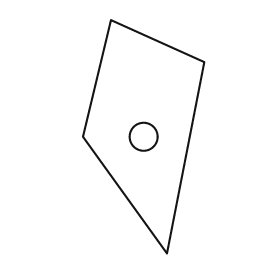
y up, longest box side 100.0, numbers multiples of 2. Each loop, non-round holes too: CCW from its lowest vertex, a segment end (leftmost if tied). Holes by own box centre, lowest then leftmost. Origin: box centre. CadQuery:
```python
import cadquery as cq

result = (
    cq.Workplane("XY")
    .moveTo(10.0, -50.0)
    .lineTo(26.0, 32.0)
    .lineTo(-14.0, 50.0)
    .lineTo(-26.0, 0.0)
    .close()
    .moveTo(0.0, 0.0)
    .circle(6.0)
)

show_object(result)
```